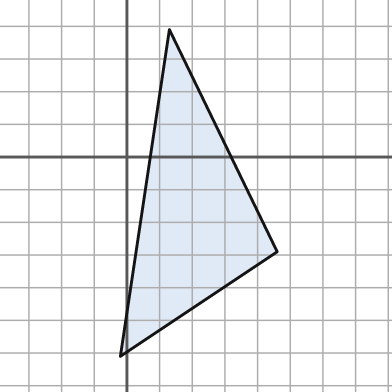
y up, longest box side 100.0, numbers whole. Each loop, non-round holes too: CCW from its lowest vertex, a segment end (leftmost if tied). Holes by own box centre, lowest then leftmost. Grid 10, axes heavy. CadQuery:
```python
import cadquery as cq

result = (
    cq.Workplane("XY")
    .moveTo(-2.0, -61.0)
    .lineTo(46.0, -29.0)
    .lineTo(13.0, 39.0)
    .close()
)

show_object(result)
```